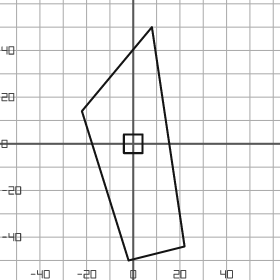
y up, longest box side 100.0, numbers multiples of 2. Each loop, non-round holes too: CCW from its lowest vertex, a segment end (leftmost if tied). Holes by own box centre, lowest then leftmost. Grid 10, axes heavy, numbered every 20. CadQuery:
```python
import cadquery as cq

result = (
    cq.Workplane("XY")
    .moveTo(-2.0, -50.0)
    .lineTo(22.0, -44.0)
    .lineTo(8.0, 50.0)
    .lineTo(-22.0, 14.0)
    .close()
    .moveTo(-4.0, -4.0)
    .lineTo(4.0, -4.0)
    .lineTo(4.0, 4.0)
    .lineTo(-4.0, 4.0)
    .close()
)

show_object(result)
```